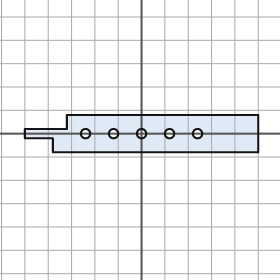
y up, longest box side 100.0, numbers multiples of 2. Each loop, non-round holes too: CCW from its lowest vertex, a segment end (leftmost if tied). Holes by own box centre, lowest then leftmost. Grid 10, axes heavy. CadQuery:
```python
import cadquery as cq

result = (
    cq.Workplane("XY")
    .moveTo(-38.0, -8.0)
    .lineTo(50.0, -8.0)
    .lineTo(50.0, 8.0)
    .lineTo(-32.0, 8.0)
    .lineTo(-32.0, 2.0)
    .lineTo(-50.0, 2.0)
    .lineTo(-50.0, -2.0)
    .lineTo(-38.0, -2.0)
    .close()
    .moveTo(-24.0, 0.0)
    .circle(2.0)
    .moveTo(-12.0, 0.0)
    .circle(2.0)
    .moveTo(0.0, 0.0)
    .circle(2.0)
    .moveTo(12.0, 0.0)
    .circle(2.0)
    .moveTo(24.0, 0.0)
    .circle(2.0)
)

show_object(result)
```